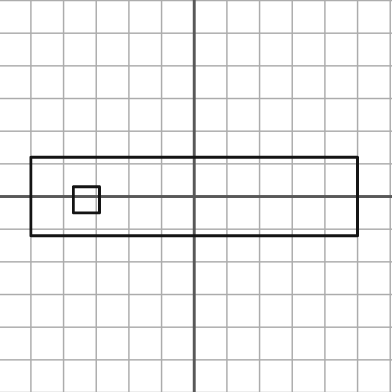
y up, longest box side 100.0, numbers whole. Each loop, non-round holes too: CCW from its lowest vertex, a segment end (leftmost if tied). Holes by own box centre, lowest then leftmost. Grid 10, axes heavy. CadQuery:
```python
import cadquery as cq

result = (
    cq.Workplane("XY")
    .moveTo(-50.0, -12.0)
    .lineTo(50.0, -12.0)
    .lineTo(50.0, 12.0)
    .lineTo(-50.0, 12.0)
    .close()
    .moveTo(-37.0, -5.0)
    .lineTo(-29.0, -5.0)
    .lineTo(-29.0, 3.0)
    .lineTo(-37.0, 3.0)
    .close()
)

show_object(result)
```